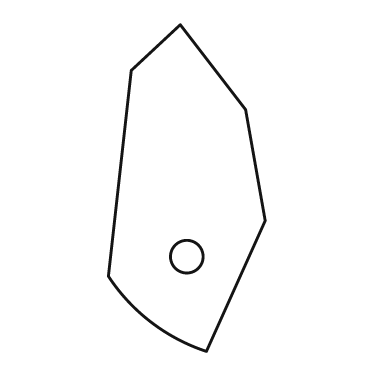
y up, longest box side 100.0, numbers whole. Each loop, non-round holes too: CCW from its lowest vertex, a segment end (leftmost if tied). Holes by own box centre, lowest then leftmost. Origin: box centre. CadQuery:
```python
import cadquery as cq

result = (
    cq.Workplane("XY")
    .moveTo(6.0, -50.0)
    .lineTo(24.0, -10.0)
    .lineTo(18.0, 24.0)
    .lineTo(-2.0, 50.0)
    .lineTo(-17.0, 36.0)
    .lineTo(-24.0, -27.0)
    .threePointArc((-11.0, -41.0), (6.0, -50.0))
    .close()
    .moveTo(0.0, -21.0)
    .circle(5.0)
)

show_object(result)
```